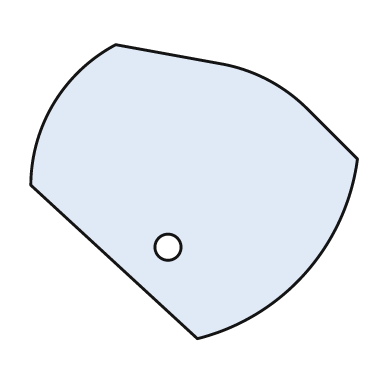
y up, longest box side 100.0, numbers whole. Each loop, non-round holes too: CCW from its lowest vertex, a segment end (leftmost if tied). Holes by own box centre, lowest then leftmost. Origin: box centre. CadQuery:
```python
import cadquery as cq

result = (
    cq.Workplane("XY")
    .moveTo(1.0, -45.0)
    .threePointArc((34.0, -25.0), (50.0, 10.0))
    .lineTo(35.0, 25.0)
    .threePointArc((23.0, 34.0), (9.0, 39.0))
    .lineTo(-24.0, 45.0)
    .threePointArc((-43.0, 27.0), (-50.0, 2.0))
    .close()
    .moveTo(-8.0, -17.0)
    .circle(4.0)
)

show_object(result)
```